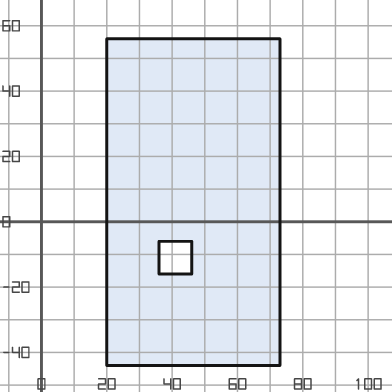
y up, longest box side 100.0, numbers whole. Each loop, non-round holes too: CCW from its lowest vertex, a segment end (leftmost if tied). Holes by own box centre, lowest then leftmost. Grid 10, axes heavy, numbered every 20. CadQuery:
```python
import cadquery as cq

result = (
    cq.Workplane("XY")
    .moveTo(20.0, -44.0)
    .lineTo(73.0, -44.0)
    .lineTo(73.0, 56.0)
    .lineTo(20.0, 56.0)
    .close()
    .moveTo(36.0, -16.0)
    .lineTo(46.0, -16.0)
    .lineTo(46.0, -6.0)
    .lineTo(36.0, -6.0)
    .close()
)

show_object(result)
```